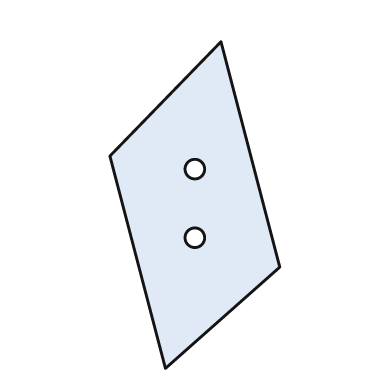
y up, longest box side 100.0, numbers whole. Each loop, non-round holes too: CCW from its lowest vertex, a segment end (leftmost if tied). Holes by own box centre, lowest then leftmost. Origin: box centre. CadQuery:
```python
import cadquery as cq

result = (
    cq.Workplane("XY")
    .moveTo(-9.0, -50.0)
    .lineTo(26.0, -19.0)
    .lineTo(8.0, 50.0)
    .lineTo(-26.0, 15.0)
    .close()
    .moveTo(0.0, -10.0)
    .circle(3.0)
    .moveTo(0.0, 11.0)
    .circle(3.0)
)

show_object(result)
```